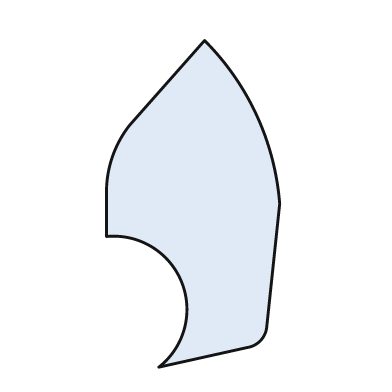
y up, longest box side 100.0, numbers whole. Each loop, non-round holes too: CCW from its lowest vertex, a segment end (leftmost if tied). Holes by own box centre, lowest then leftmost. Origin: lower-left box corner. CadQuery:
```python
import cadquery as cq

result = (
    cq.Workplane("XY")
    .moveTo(16.0, 0.0)
    .lineTo(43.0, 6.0)
    .threePointArc((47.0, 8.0), (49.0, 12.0))
    .lineTo(53.0, 50.0)
    .threePointArc((46.0, 77.0), (30.0, 100.0))
    .lineTo(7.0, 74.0)
    .threePointArc((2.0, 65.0), (0.0, 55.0))
    .lineTo(0.0, 40.0)
    .threePointArc((23.0, 26.0), (16.0, 0.0))
    .close()
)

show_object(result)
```